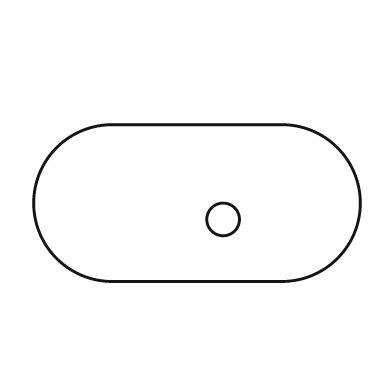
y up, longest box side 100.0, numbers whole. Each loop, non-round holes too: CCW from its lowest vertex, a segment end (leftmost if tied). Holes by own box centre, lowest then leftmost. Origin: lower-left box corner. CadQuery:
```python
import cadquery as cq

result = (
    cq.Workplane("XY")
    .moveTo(24.0, 0.0)
    .lineTo(76.0, 0.0)
    .threePointArc((100.0, 24.0), (76.0, 48.0))
    .lineTo(24.0, 48.0)
    .threePointArc((0.0, 24.0), (24.0, 0.0))
    .close()
    .moveTo(58.0, 19.0)
    .circle(5.0)
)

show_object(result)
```